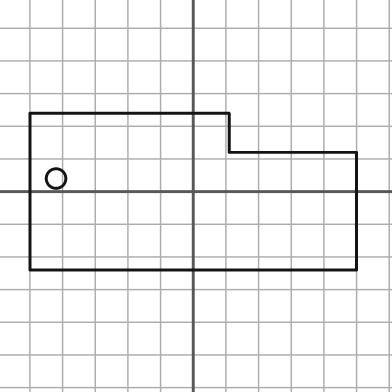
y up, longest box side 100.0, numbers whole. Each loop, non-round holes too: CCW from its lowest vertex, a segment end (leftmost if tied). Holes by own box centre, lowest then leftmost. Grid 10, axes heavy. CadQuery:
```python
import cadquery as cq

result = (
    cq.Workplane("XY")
    .moveTo(-50.0, -24.0)
    .lineTo(50.0, -24.0)
    .lineTo(50.0, 12.0)
    .lineTo(11.0, 12.0)
    .lineTo(11.0, 24.0)
    .lineTo(-50.0, 24.0)
    .close()
    .moveTo(-42.0, 4.0)
    .circle(3.0)
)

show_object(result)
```